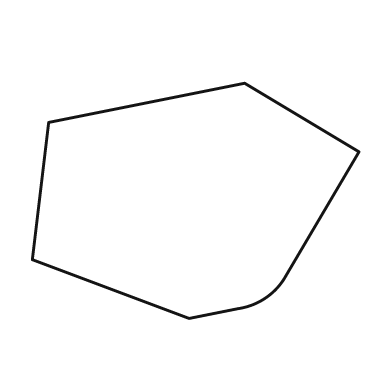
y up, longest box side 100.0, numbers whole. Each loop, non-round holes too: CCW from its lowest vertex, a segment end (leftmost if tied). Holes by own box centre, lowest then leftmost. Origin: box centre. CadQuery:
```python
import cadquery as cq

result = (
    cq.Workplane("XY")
    .moveTo(-2.0, -36.0)
    .lineTo(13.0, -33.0)
    .threePointArc((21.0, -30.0), (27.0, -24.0))
    .lineTo(50.0, 15.0)
    .lineTo(15.0, 36.0)
    .lineTo(-45.0, 24.0)
    .lineTo(-50.0, -18.0)
    .close()
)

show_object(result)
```